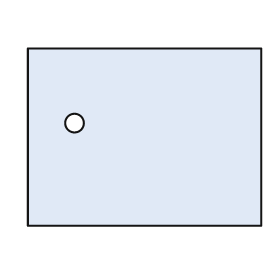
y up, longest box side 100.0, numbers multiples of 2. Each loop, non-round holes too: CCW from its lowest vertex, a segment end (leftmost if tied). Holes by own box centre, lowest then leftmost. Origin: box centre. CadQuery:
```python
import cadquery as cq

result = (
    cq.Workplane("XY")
    .moveTo(-50.0, -38.0)
    .lineTo(50.0, -38.0)
    .lineTo(50.0, 38.0)
    .lineTo(-50.0, 38.0)
    .close()
    .moveTo(-30.0, 6.0)
    .circle(4.0)
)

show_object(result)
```